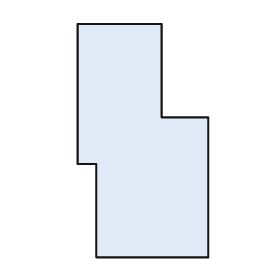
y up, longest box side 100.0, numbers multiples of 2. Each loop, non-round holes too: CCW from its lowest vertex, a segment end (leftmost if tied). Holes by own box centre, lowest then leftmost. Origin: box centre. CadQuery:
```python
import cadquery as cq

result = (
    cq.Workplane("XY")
    .moveTo(-20.0, -50.0)
    .lineTo(28.0, -50.0)
    .lineTo(28.0, 10.0)
    .lineTo(8.0, 10.0)
    .lineTo(8.0, 50.0)
    .lineTo(-28.0, 50.0)
    .lineTo(-28.0, -10.0)
    .lineTo(-20.0, -10.0)
    .close()
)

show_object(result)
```